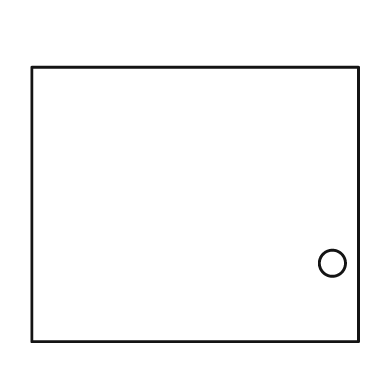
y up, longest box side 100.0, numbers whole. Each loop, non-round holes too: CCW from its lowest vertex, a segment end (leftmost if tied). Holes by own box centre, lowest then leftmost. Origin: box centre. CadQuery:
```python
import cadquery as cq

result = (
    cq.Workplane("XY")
    .moveTo(-50.0, -42.0)
    .lineTo(50.0, -42.0)
    .lineTo(50.0, 42.0)
    .lineTo(-50.0, 42.0)
    .close()
    .moveTo(42.0, -18.0)
    .circle(4.0)
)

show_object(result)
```